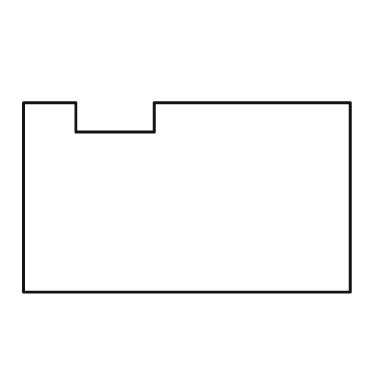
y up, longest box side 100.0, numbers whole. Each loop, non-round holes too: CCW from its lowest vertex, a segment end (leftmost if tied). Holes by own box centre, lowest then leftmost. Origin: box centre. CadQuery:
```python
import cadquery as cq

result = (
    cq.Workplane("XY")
    .moveTo(-50.0, -29.0)
    .lineTo(50.0, -29.0)
    .lineTo(50.0, 29.0)
    .lineTo(-10.0, 29.0)
    .lineTo(-10.0, 20.0)
    .lineTo(-34.0, 20.0)
    .lineTo(-34.0, 29.0)
    .lineTo(-50.0, 29.0)
    .close()
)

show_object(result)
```